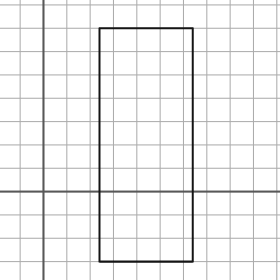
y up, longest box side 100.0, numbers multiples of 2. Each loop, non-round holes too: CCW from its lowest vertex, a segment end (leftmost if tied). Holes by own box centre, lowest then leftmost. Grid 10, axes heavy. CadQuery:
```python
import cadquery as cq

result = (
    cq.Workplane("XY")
    .moveTo(24.0, -30.0)
    .lineTo(64.0, -30.0)
    .lineTo(64.0, 70.0)
    .lineTo(24.0, 70.0)
    .close()
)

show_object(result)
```